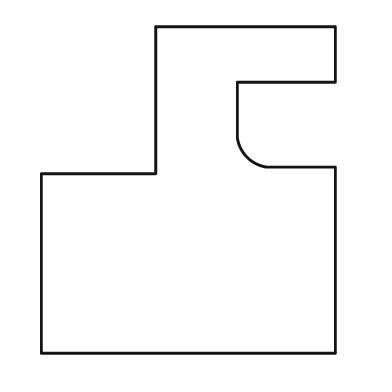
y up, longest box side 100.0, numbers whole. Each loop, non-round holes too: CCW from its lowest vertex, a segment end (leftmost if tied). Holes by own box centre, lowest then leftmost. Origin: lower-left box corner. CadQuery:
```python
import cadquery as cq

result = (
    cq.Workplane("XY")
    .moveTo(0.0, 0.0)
    .lineTo(90.0, 0.0)
    .lineTo(90.0, 57.0)
    .lineTo(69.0, 57.0)
    .threePointArc((63.0, 60.0), (60.0, 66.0))
    .lineTo(60.0, 83.0)
    .lineTo(90.0, 83.0)
    .lineTo(90.0, 100.0)
    .lineTo(35.0, 100.0)
    .lineTo(35.0, 55.0)
    .lineTo(0.0, 55.0)
    .close()
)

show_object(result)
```